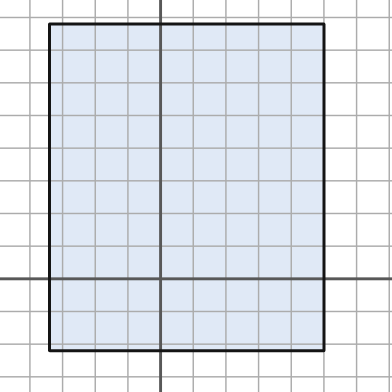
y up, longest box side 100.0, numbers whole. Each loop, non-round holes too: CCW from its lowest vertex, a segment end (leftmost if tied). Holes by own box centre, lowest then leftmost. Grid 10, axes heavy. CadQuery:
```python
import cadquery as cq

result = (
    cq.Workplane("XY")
    .moveTo(-34.0, -22.0)
    .lineTo(50.0, -22.0)
    .lineTo(50.0, 78.0)
    .lineTo(-34.0, 78.0)
    .close()
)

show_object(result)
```